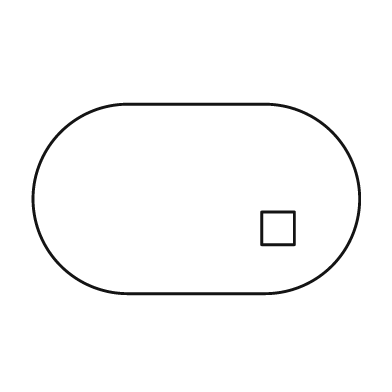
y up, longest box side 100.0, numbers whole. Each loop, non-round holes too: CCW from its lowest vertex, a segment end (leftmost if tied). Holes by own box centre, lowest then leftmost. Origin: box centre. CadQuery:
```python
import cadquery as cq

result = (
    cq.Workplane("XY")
    .moveTo(-21.0, -29.0)
    .lineTo(21.0, -29.0)
    .threePointArc((50.0, 0.0), (21.0, 29.0))
    .lineTo(-21.0, 29.0)
    .threePointArc((-50.0, 0.0), (-21.0, -29.0))
    .close()
    .moveTo(20.0, -14.0)
    .lineTo(30.0, -14.0)
    .lineTo(30.0, -4.0)
    .lineTo(20.0, -4.0)
    .close()
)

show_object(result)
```